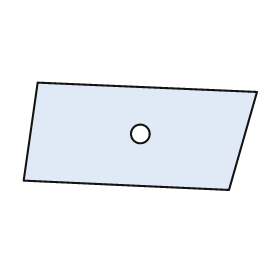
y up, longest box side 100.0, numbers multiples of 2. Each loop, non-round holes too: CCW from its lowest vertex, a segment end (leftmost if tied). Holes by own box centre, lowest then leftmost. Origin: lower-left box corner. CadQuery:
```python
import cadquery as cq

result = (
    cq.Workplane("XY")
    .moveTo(88.0, 0.0)
    .lineTo(100.0, 42.0)
    .lineTo(6.0, 46.0)
    .lineTo(0.0, 4.0)
    .close()
    .moveTo(50.0, 24.0)
    .circle(4.0)
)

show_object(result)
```